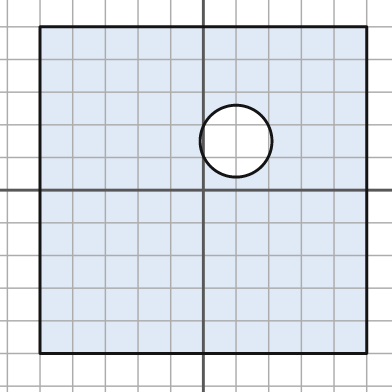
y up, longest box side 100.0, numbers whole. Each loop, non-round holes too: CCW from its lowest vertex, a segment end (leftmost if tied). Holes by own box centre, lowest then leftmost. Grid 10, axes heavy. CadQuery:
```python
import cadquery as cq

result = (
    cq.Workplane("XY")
    .moveTo(-50.0, -50.0)
    .lineTo(50.0, -50.0)
    .lineTo(50.0, 50.0)
    .lineTo(-50.0, 50.0)
    .close()
    .moveTo(10.0, 15.0)
    .circle(11.0)
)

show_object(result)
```